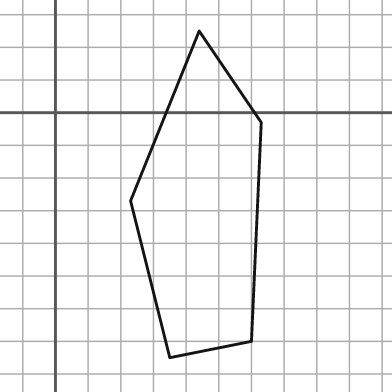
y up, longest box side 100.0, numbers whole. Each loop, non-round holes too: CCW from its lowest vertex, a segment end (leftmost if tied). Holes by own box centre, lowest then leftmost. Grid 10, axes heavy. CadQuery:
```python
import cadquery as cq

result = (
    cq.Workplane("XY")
    .moveTo(35.0, -75.0)
    .lineTo(60.0, -70.0)
    .lineTo(63.0, -3.0)
    .lineTo(44.0, 25.0)
    .lineTo(23.0, -27.0)
    .close()
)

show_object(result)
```